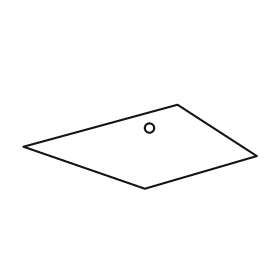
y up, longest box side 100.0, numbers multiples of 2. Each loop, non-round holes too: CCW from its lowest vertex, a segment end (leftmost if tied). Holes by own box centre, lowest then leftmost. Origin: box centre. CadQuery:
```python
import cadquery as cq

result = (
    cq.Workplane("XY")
    .moveTo(2.0, -18.0)
    .lineTo(50.0, -4.0)
    .lineTo(16.0, 18.0)
    .lineTo(-50.0, 0.0)
    .close()
    .moveTo(4.0, 8.0)
    .circle(2.0)
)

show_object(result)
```